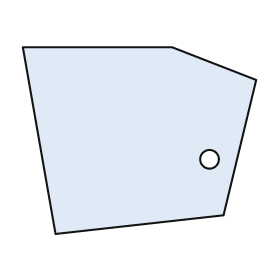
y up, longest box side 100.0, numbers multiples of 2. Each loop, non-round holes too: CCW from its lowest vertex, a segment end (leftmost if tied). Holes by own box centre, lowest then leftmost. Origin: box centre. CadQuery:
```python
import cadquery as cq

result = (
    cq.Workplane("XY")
    .moveTo(-36.0, -40.0)
    .lineTo(36.0, -32.0)
    .lineTo(50.0, 26.0)
    .lineTo(14.0, 40.0)
    .lineTo(-50.0, 40.0)
    .close()
    .moveTo(30.0, -8.0)
    .circle(4.0)
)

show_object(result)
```